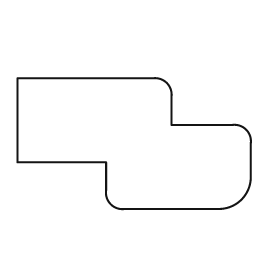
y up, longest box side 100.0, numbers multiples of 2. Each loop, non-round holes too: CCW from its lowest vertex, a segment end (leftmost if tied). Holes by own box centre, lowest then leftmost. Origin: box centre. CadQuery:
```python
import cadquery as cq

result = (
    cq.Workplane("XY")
    .moveTo(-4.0, -28.0)
    .lineTo(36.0, -28.0)
    .threePointArc((46.0, -24.0), (50.0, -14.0))
    .lineTo(50.0, 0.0)
    .threePointArc((48.0, 6.0), (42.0, 8.0))
    .lineTo(16.0, 8.0)
    .lineTo(16.0, 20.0)
    .threePointArc((14.0, 26.0), (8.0, 28.0))
    .lineTo(-50.0, 28.0)
    .lineTo(-50.0, -8.0)
    .lineTo(-12.0, -8.0)
    .lineTo(-12.0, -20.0)
    .threePointArc((-10.0, -26.0), (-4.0, -28.0))
    .close()
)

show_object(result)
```